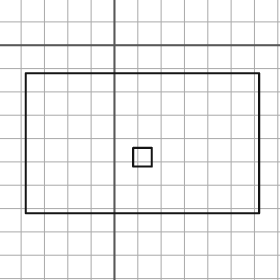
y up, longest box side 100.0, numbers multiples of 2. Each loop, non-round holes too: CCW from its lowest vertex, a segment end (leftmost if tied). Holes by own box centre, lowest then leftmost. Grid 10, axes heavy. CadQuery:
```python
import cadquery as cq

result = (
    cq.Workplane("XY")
    .moveTo(-38.0, -72.0)
    .lineTo(62.0, -72.0)
    .lineTo(62.0, -12.0)
    .lineTo(-38.0, -12.0)
    .close()
    .moveTo(8.0, -52.0)
    .lineTo(16.0, -52.0)
    .lineTo(16.0, -44.0)
    .lineTo(8.0, -44.0)
    .close()
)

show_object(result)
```